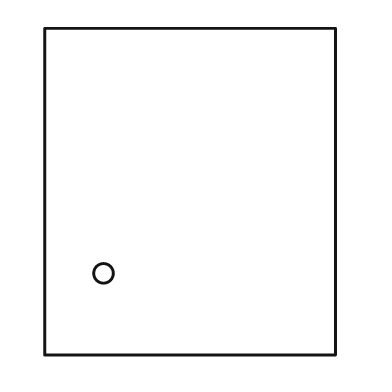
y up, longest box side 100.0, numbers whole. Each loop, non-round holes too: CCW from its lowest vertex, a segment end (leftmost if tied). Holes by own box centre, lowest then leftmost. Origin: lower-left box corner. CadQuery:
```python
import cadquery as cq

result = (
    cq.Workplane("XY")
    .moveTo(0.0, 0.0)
    .lineTo(89.0, 0.0)
    .lineTo(89.0, 100.0)
    .lineTo(0.0, 100.0)
    .close()
    .moveTo(18.0, 25.0)
    .circle(3.0)
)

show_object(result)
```